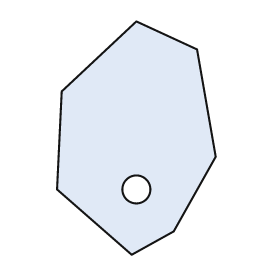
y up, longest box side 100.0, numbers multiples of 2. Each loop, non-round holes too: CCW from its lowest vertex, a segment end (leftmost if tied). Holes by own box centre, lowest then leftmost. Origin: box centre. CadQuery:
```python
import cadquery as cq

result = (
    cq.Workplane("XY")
    .moveTo(-2.0, -50.0)
    .lineTo(16.0, -40.0)
    .lineTo(34.0, -8.0)
    .lineTo(26.0, 38.0)
    .lineTo(0.0, 50.0)
    .lineTo(-32.0, 20.0)
    .lineTo(-34.0, -22.0)
    .close()
    .moveTo(0.0, -22.0)
    .circle(6.0)
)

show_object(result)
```